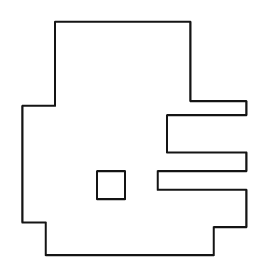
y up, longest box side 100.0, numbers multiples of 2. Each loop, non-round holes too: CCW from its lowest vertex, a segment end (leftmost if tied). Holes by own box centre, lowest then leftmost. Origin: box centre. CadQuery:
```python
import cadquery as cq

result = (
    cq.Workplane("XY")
    .moveTo(-38.0, -50.0)
    .lineTo(34.0, -50.0)
    .lineTo(34.0, -38.0)
    .lineTo(48.0, -38.0)
    .lineTo(48.0, -22.0)
    .lineTo(10.0, -22.0)
    .lineTo(10.0, -14.0)
    .lineTo(48.0, -14.0)
    .lineTo(48.0, -6.0)
    .lineTo(14.0, -6.0)
    .lineTo(14.0, 10.0)
    .lineTo(48.0, 10.0)
    .lineTo(48.0, 16.0)
    .lineTo(24.0, 16.0)
    .lineTo(24.0, 50.0)
    .lineTo(-34.0, 50.0)
    .lineTo(-34.0, 14.0)
    .lineTo(-48.0, 14.0)
    .lineTo(-48.0, -36.0)
    .lineTo(-38.0, -36.0)
    .close()
    .moveTo(-16.0, -26.0)
    .lineTo(-4.0, -26.0)
    .lineTo(-4.0, -14.0)
    .lineTo(-16.0, -14.0)
    .close()
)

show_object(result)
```